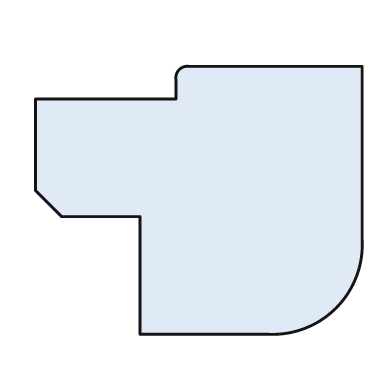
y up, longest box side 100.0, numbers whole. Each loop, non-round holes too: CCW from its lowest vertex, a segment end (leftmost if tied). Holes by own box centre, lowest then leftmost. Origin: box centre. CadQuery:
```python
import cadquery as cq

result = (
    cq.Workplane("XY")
    .moveTo(-18.0, -41.0)
    .lineTo(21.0, -41.0)
    .threePointArc((42.0, -33.0), (50.0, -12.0))
    .lineTo(50.0, 41.0)
    .lineTo(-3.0, 41.0)
    .threePointArc((-6.0, 40.0), (-7.0, 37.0))
    .lineTo(-7.0, 31.0)
    .lineTo(-50.0, 31.0)
    .lineTo(-50.0, 3.0)
    .lineTo(-42.0, -5.0)
    .lineTo(-18.0, -5.0)
    .close()
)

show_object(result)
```